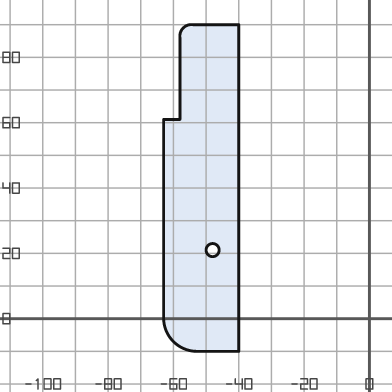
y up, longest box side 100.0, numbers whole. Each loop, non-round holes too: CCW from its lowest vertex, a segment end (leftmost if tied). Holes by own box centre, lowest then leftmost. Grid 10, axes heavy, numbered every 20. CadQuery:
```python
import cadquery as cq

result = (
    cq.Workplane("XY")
    .moveTo(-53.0, -10.0)
    .lineTo(-40.0, -10.0)
    .lineTo(-40.0, 90.0)
    .lineTo(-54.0, 90.0)
    .threePointArc((-57.0, 89.0), (-58.0, 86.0))
    .lineTo(-58.0, 61.0)
    .lineTo(-63.0, 61.0)
    .lineTo(-63.0, 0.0)
    .threePointArc((-60.0, -7.0), (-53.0, -10.0))
    .close()
    .moveTo(-48.0, 21.0)
    .circle(2.0)
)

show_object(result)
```